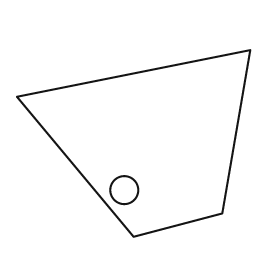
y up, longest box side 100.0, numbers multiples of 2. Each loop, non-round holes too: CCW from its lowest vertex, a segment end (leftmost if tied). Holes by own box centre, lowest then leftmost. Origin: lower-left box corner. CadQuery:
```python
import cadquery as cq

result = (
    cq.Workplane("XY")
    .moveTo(50.0, 0.0)
    .lineTo(88.0, 10.0)
    .lineTo(100.0, 80.0)
    .lineTo(0.0, 60.0)
    .close()
    .moveTo(46.0, 20.0)
    .circle(6.0)
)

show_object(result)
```